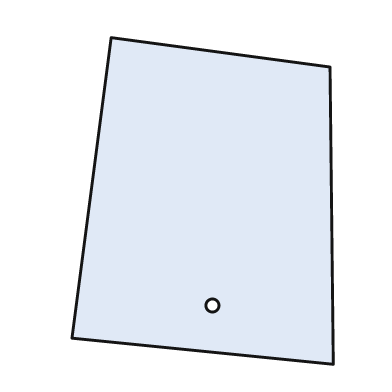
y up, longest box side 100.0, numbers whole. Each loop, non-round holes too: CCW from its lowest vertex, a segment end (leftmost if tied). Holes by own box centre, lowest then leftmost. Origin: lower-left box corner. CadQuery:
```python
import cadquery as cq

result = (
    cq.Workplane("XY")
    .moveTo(80.0, 0.0)
    .lineTo(79.0, 91.0)
    .lineTo(12.0, 100.0)
    .lineTo(0.0, 8.0)
    .close()
    .moveTo(43.0, 18.0)
    .circle(2.0)
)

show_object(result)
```